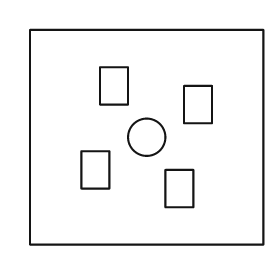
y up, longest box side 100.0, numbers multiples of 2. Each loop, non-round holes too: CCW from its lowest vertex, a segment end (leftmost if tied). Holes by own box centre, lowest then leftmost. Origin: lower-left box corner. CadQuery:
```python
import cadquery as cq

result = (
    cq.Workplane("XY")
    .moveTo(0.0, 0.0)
    .lineTo(100.0, 0.0)
    .lineTo(100.0, 92.0)
    .lineTo(0.0, 92.0)
    .close()
    .moveTo(58.0, 16.0)
    .lineTo(70.0, 16.0)
    .lineTo(70.0, 32.0)
    .lineTo(58.0, 32.0)
    .close()
    .moveTo(22.0, 24.0)
    .lineTo(34.0, 24.0)
    .lineTo(34.0, 40.0)
    .lineTo(22.0, 40.0)
    .close()
    .moveTo(50.0, 46.0)
    .circle(8.0)
    .moveTo(66.0, 52.0)
    .lineTo(78.0, 52.0)
    .lineTo(78.0, 68.0)
    .lineTo(66.0, 68.0)
    .close()
    .moveTo(30.0, 60.0)
    .lineTo(42.0, 60.0)
    .lineTo(42.0, 76.0)
    .lineTo(30.0, 76.0)
    .close()
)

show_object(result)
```